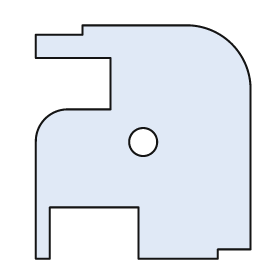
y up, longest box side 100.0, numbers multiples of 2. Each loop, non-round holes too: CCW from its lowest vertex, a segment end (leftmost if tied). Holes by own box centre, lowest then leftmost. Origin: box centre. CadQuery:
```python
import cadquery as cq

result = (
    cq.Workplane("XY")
    .moveTo(-46.0, -50.0)
    .lineTo(-40.0, -50.0)
    .lineTo(-40.0, -28.0)
    .lineTo(-2.0, -28.0)
    .lineTo(-2.0, -50.0)
    .lineTo(32.0, -50.0)
    .lineTo(32.0, -46.0)
    .lineTo(46.0, -46.0)
    .lineTo(46.0, 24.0)
    .threePointArc((38.0, 42.0), (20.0, 50.0))
    .lineTo(-26.0, 50.0)
    .lineTo(-26.0, 46.0)
    .lineTo(-46.0, 46.0)
    .lineTo(-46.0, 36.0)
    .lineTo(-14.0, 36.0)
    .lineTo(-14.0, 14.0)
    .lineTo(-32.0, 14.0)
    .threePointArc((-42.0, 10.0), (-46.0, 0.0))
    .close()
    .moveTo(0.0, 0.0)
    .circle(6.0)
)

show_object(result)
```